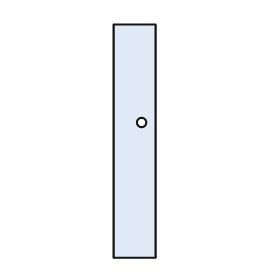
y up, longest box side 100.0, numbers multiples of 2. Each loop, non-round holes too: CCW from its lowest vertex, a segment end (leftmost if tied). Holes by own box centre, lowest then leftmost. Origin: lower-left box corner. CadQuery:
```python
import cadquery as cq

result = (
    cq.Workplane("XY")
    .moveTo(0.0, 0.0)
    .lineTo(18.0, 0.0)
    .lineTo(18.0, 100.0)
    .lineTo(0.0, 100.0)
    .close()
    .moveTo(12.0, 58.0)
    .circle(2.0)
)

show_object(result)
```